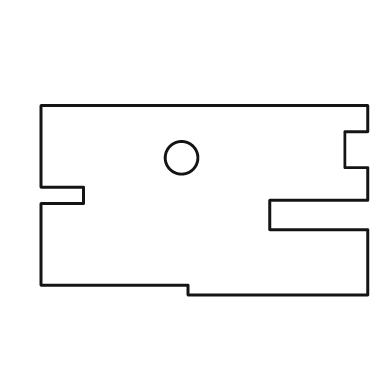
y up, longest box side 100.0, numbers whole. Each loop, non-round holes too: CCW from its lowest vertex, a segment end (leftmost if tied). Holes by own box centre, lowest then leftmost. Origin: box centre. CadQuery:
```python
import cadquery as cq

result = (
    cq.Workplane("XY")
    .moveTo(-5.0, -29.0)
    .lineTo(50.0, -29.0)
    .lineTo(50.0, -9.0)
    .lineTo(20.0, -9.0)
    .lineTo(20.0, 0.0)
    .lineTo(50.0, 0.0)
    .lineTo(50.0, 10.0)
    .lineTo(43.0, 10.0)
    .lineTo(43.0, 21.0)
    .lineTo(50.0, 21.0)
    .lineTo(50.0, 29.0)
    .lineTo(-50.0, 29.0)
    .lineTo(-50.0, 4.0)
    .lineTo(-37.0, 4.0)
    .lineTo(-37.0, -1.0)
    .lineTo(-50.0, -1.0)
    .lineTo(-50.0, -26.0)
    .lineTo(-5.0, -26.0)
    .close()
    .moveTo(-7.0, 13.0)
    .circle(5.0)
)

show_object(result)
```